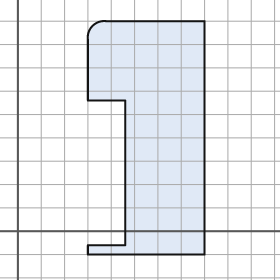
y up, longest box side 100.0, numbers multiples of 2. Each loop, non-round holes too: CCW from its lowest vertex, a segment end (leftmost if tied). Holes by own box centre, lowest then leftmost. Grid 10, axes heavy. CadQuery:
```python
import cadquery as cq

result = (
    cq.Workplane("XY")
    .moveTo(30.0, -10.0)
    .lineTo(80.0, -10.0)
    .lineTo(80.0, 90.0)
    .lineTo(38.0, 90.0)
    .threePointArc((32.0, 88.0), (30.0, 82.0))
    .lineTo(30.0, 56.0)
    .lineTo(46.0, 56.0)
    .lineTo(46.0, -6.0)
    .lineTo(30.0, -6.0)
    .close()
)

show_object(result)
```